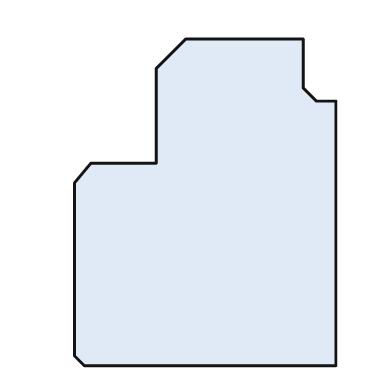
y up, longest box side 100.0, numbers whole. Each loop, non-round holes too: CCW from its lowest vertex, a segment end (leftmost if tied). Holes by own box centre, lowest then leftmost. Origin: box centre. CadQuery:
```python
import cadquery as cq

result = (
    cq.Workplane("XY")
    .moveTo(-37.0, -50.0)
    .lineTo(40.0, -50.0)
    .lineTo(40.0, 31.0)
    .lineTo(34.0, 31.0)
    .lineTo(30.0, 35.0)
    .lineTo(30.0, 50.0)
    .lineTo(-6.0, 50.0)
    .lineTo(-15.0, 41.0)
    .lineTo(-15.0, 12.0)
    .lineTo(-35.0, 12.0)
    .lineTo(-40.0, 6.0)
    .lineTo(-40.0, -47.0)
    .close()
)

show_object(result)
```